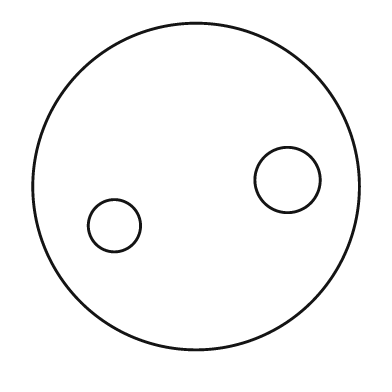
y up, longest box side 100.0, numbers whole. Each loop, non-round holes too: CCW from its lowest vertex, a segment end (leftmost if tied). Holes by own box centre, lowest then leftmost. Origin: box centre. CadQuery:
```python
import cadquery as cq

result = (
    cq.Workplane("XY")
    .moveTo(0.0, 0.0)
    .circle(50.0)
    .moveTo(-25.0, -12.0)
    .circle(8.0)
    .moveTo(28.0, 2.0)
    .circle(10.0)
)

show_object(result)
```